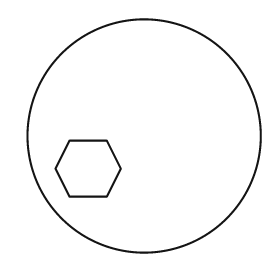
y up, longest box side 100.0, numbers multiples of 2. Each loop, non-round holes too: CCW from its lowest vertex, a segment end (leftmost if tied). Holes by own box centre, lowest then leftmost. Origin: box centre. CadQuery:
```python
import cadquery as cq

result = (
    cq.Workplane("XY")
    .moveTo(0.0, 0.0)
    .circle(50.0)
    .moveTo(-32.0, -26.0)
    .lineTo(-16.0, -26.0)
    .lineTo(-10.0, -14.0)
    .lineTo(-16.0, -2.0)
    .lineTo(-32.0, -2.0)
    .lineTo(-38.0, -14.0)
    .close()
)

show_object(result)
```